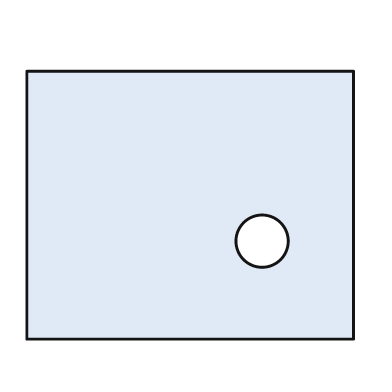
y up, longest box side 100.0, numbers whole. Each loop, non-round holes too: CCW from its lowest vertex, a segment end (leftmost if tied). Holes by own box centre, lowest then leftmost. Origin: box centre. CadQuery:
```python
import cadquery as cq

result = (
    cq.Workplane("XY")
    .moveTo(-50.0, -41.0)
    .lineTo(50.0, -41.0)
    .lineTo(50.0, 41.0)
    .lineTo(-50.0, 41.0)
    .close()
    .moveTo(22.0, -11.0)
    .circle(8.0)
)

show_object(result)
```